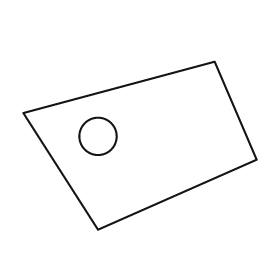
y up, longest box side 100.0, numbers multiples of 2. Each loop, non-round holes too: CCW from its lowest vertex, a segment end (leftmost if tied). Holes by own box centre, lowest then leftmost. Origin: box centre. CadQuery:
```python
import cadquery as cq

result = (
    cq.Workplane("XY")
    .moveTo(-18.0, -36.0)
    .lineTo(50.0, -6.0)
    .lineTo(32.0, 36.0)
    .lineTo(-50.0, 14.0)
    .close()
    .moveTo(-18.0, 4.0)
    .circle(8.0)
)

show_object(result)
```